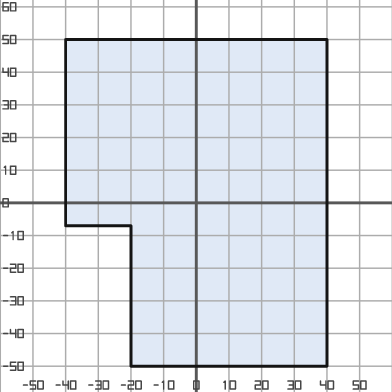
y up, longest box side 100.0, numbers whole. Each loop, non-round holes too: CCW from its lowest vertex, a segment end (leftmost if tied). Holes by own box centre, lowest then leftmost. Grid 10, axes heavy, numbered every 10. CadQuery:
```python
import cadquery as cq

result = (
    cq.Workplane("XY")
    .moveTo(-20.0, -50.0)
    .lineTo(40.0, -50.0)
    .lineTo(40.0, 50.0)
    .lineTo(-40.0, 50.0)
    .lineTo(-40.0, -7.0)
    .lineTo(-20.0, -7.0)
    .close()
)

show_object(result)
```